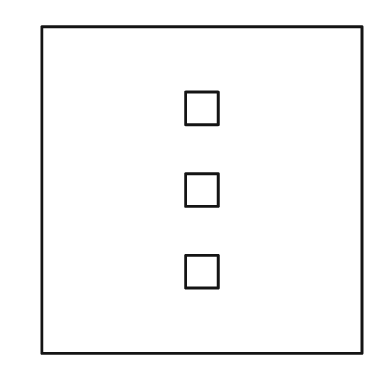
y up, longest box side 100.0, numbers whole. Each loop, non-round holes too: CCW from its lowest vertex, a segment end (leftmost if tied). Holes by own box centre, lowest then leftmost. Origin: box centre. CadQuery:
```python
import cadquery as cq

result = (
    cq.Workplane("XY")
    .moveTo(-49.0, -50.0)
    .lineTo(49.0, -50.0)
    .lineTo(49.0, 50.0)
    .lineTo(-49.0, 50.0)
    .close()
    .moveTo(-5.0, -30.0)
    .lineTo(5.0, -30.0)
    .lineTo(5.0, -20.0)
    .lineTo(-5.0, -20.0)
    .close()
    .moveTo(-5.0, -5.0)
    .lineTo(5.0, -5.0)
    .lineTo(5.0, 5.0)
    .lineTo(-5.0, 5.0)
    .close()
    .moveTo(-5.0, 20.0)
    .lineTo(5.0, 20.0)
    .lineTo(5.0, 30.0)
    .lineTo(-5.0, 30.0)
    .close()
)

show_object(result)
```